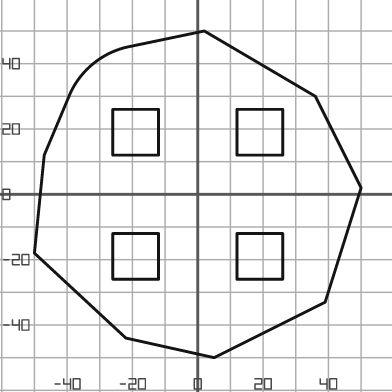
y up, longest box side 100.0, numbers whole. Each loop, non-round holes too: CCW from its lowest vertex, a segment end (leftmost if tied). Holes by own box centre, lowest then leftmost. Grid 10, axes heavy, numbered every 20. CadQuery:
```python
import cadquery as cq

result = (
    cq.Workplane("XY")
    .moveTo(5.0, -50.0)
    .lineTo(39.0, -33.0)
    .lineTo(50.0, 2.0)
    .lineTo(36.0, 30.0)
    .lineTo(2.0, 50.0)
    .lineTo(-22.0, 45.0)
    .threePointArc((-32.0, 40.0), (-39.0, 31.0))
    .lineTo(-47.0, 12.0)
    .lineTo(-50.0, -18.0)
    .lineTo(-22.0, -44.0)
    .close()
    .moveTo(-26.0, -26.0)
    .lineTo(-12.0, -26.0)
    .lineTo(-12.0, -12.0)
    .lineTo(-26.0, -12.0)
    .close()
    .moveTo(12.0, -26.0)
    .lineTo(26.0, -26.0)
    .lineTo(26.0, -12.0)
    .lineTo(12.0, -12.0)
    .close()
    .moveTo(-26.0, 12.0)
    .lineTo(-12.0, 12.0)
    .lineTo(-12.0, 26.0)
    .lineTo(-26.0, 26.0)
    .close()
    .moveTo(12.0, 12.0)
    .lineTo(26.0, 12.0)
    .lineTo(26.0, 26.0)
    .lineTo(12.0, 26.0)
    .close()
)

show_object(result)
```